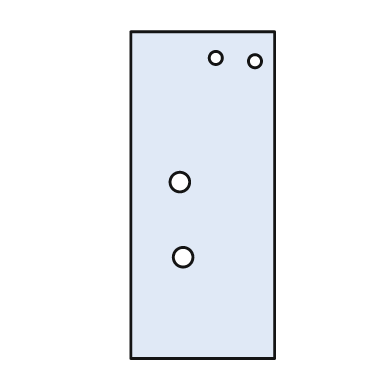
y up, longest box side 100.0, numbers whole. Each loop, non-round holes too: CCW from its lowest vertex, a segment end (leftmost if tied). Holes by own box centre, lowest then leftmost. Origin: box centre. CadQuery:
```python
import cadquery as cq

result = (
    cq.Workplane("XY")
    .moveTo(-22.0, -50.0)
    .lineTo(22.0, -50.0)
    .lineTo(22.0, 50.0)
    .lineTo(-22.0, 50.0)
    .close()
    .moveTo(-6.0, -19.0)
    .circle(3.0)
    .moveTo(-7.0, 4.0)
    .circle(3.0)
    .moveTo(16.0, 41.0)
    .circle(2.0)
    .moveTo(4.0, 42.0)
    .circle(2.0)
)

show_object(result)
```